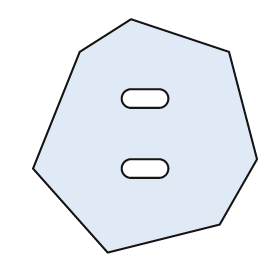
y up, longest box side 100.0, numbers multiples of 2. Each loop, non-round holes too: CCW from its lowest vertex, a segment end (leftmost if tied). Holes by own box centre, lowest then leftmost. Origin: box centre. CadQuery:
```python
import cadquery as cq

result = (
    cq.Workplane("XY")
    .moveTo(-16.0, -50.0)
    .lineTo(32.0, -38.0)
    .lineTo(48.0, -10.0)
    .lineTo(36.0, 36.0)
    .lineTo(-6.0, 50.0)
    .lineTo(-28.0, 36.0)
    .lineTo(-48.0, -14.0)
    .close()
    .moveTo(-6.0, -18.0)
    .lineTo(6.0, -18.0)
    .threePointArc((10.0, -14.0), (6.0, -10.0))
    .lineTo(-6.0, -10.0)
    .threePointArc((-10.0, -14.0), (-6.0, -18.0))
    .close()
    .moveTo(-6.0, 12.0)
    .lineTo(6.0, 12.0)
    .threePointArc((10.0, 16.0), (6.0, 20.0))
    .lineTo(-6.0, 20.0)
    .threePointArc((-10.0, 16.0), (-6.0, 12.0))
    .close()
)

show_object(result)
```